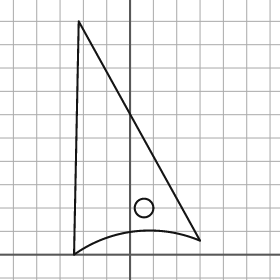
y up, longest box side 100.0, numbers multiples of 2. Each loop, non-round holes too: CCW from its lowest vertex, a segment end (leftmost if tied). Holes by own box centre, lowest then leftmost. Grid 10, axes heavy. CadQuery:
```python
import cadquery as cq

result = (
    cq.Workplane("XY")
    .moveTo(-24.0, 0.0)
    .threePointArc((2.0, 10.0), (30.0, 6.0))
    .lineTo(-22.0, 100.0)
    .close()
    .moveTo(6.0, 20.0)
    .circle(4.0)
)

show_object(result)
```